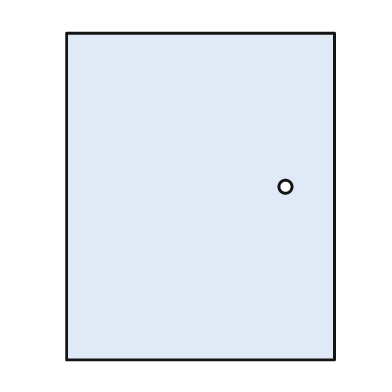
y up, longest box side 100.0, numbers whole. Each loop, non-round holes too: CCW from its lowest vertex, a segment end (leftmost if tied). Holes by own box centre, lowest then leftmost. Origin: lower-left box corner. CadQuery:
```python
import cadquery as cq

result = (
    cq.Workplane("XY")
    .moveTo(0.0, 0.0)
    .lineTo(82.0, 0.0)
    .lineTo(82.0, 100.0)
    .lineTo(0.0, 100.0)
    .close()
    .moveTo(67.0, 53.0)
    .circle(2.0)
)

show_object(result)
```